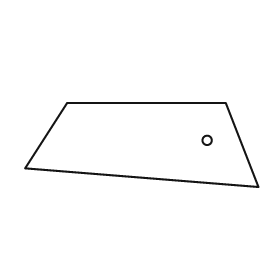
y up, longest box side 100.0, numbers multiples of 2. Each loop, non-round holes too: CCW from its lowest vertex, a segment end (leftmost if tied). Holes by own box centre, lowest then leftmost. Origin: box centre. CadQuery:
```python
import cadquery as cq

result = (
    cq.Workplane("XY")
    .moveTo(50.0, -18.0)
    .lineTo(36.0, 18.0)
    .lineTo(-32.0, 18.0)
    .lineTo(-50.0, -10.0)
    .close()
    .moveTo(28.0, 2.0)
    .circle(2.0)
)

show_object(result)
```